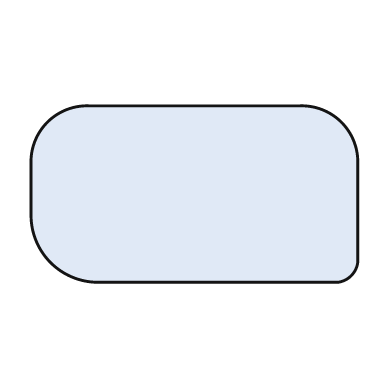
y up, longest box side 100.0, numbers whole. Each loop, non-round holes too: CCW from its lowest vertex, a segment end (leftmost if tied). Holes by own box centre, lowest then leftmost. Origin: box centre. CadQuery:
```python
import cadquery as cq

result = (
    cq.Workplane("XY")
    .moveTo(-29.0, -27.0)
    .lineTo(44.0, -27.0)
    .threePointArc((48.0, -25.0), (50.0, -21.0))
    .lineTo(50.0, 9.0)
    .threePointArc((45.0, 22.0), (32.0, 27.0))
    .lineTo(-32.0, 27.0)
    .threePointArc((-45.0, 22.0), (-50.0, 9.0))
    .lineTo(-50.0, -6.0)
    .threePointArc((-44.0, -21.0), (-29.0, -27.0))
    .close()
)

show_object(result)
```